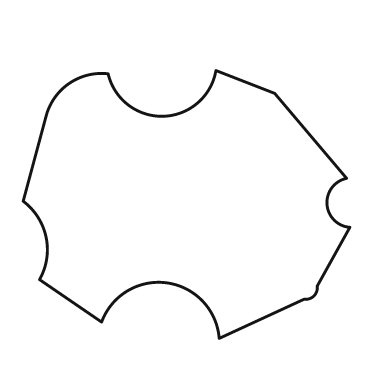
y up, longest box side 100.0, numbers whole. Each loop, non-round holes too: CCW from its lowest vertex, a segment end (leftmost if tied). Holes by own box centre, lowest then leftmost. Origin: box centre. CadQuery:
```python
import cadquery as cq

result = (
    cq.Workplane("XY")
    .moveTo(10.0, -41.0)
    .lineTo(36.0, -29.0)
    .threePointArc((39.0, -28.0), (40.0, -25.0))
    .lineTo(50.0, -7.0)
    .threePointArc((43.0, 0.0), (49.0, 8.0))
    .lineTo(27.0, 34.0)
    .lineTo(9.0, 41.0)
    .threePointArc((-7.0, 27.0), (-24.0, 40.0))
    .threePointArc((-36.0, 37.0), (-43.0, 27.0))
    .lineTo(-50.0, 1.0)
    .threePointArc((-43.0, -10.0), (-45.0, -23.0))
    .lineTo(-26.0, -36.0)
    .threePointArc((-6.0, -24.0), (10.0, -41.0))
    .close()
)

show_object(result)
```